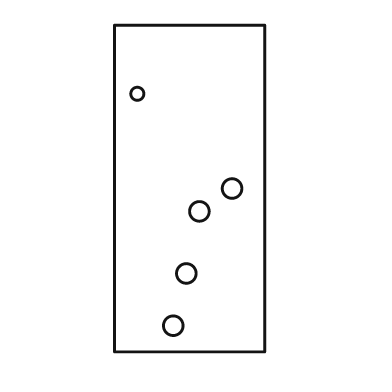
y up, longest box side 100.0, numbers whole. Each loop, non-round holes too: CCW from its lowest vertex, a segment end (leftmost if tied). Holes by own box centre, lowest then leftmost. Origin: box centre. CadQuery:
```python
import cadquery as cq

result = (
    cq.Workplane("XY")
    .moveTo(-23.0, -50.0)
    .lineTo(23.0, -50.0)
    .lineTo(23.0, 50.0)
    .lineTo(-23.0, 50.0)
    .close()
    .moveTo(-5.0, -42.0)
    .circle(3.0)
    .moveTo(-1.0, -26.0)
    .circle(3.0)
    .moveTo(3.0, -7.0)
    .circle(3.0)
    .moveTo(13.0, 0.0)
    .circle(3.0)
    .moveTo(-16.0, 29.0)
    .circle(2.0)
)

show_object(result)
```